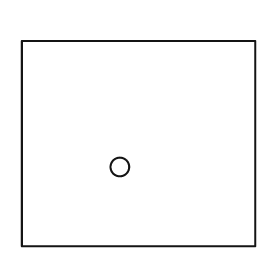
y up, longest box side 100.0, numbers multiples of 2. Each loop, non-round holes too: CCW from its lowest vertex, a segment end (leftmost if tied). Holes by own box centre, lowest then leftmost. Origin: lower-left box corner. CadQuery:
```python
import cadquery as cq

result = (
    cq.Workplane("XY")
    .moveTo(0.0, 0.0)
    .lineTo(100.0, 0.0)
    .lineTo(100.0, 88.0)
    .lineTo(0.0, 88.0)
    .close()
    .moveTo(42.0, 34.0)
    .circle(4.0)
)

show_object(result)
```